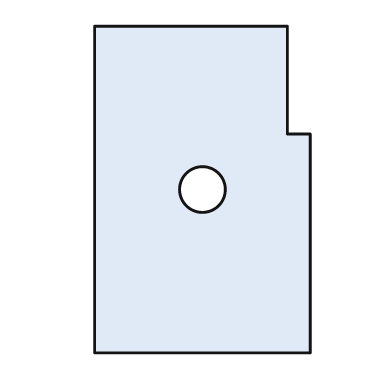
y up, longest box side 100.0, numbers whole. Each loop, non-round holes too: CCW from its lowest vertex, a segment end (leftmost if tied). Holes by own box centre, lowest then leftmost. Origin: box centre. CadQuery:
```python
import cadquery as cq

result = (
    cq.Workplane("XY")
    .moveTo(-33.0, -50.0)
    .lineTo(33.0, -50.0)
    .lineTo(33.0, 17.0)
    .lineTo(26.0, 17.0)
    .lineTo(26.0, 50.0)
    .lineTo(-33.0, 50.0)
    .close()
    .moveTo(0.0, 0.0)
    .circle(7.0)
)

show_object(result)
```